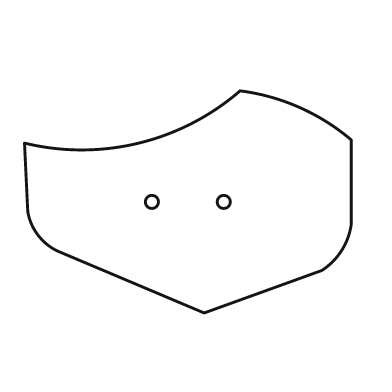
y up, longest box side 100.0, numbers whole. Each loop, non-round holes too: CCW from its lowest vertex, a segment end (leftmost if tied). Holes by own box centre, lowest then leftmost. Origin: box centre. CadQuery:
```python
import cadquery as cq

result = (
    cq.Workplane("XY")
    .moveTo(5.0, -34.0)
    .lineTo(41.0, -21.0)
    .threePointArc((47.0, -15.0), (50.0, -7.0))
    .lineTo(50.0, 19.0)
    .threePointArc((34.0, 29.0), (16.0, 34.0))
    .threePointArc((-15.0, 18.0), (-50.0, 18.0))
    .lineTo(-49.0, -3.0)
    .threePointArc((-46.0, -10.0), (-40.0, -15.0))
    .close()
    .moveTo(-11.0, 0.0)
    .circle(2.0)
    .moveTo(11.0, 0.0)
    .circle(2.0)
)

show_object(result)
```